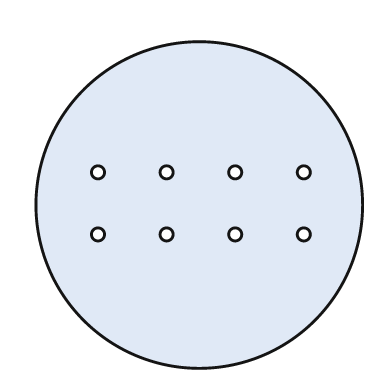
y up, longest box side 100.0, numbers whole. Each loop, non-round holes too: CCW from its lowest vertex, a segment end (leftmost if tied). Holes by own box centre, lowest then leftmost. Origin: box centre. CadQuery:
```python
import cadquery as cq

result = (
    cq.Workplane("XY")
    .moveTo(0.0, 0.0)
    .circle(50.0)
    .moveTo(-31.0, -9.0)
    .circle(2.0)
    .moveTo(-10.0, -9.0)
    .circle(2.0)
    .moveTo(11.0, -9.0)
    .circle(2.0)
    .moveTo(32.0, -9.0)
    .circle(2.0)
    .moveTo(-31.0, 10.0)
    .circle(2.0)
    .moveTo(-10.0, 10.0)
    .circle(2.0)
    .moveTo(11.0, 10.0)
    .circle(2.0)
    .moveTo(32.0, 10.0)
    .circle(2.0)
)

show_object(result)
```